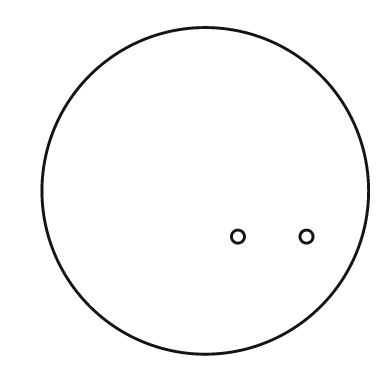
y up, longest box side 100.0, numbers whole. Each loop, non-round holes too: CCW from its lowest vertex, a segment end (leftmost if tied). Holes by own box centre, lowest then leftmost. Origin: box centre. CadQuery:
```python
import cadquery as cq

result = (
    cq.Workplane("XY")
    .moveTo(0.0, 0.0)
    .circle(50.0)
    .moveTo(10.0, -14.0)
    .circle(2.0)
    .moveTo(31.0, -14.0)
    .circle(2.0)
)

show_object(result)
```